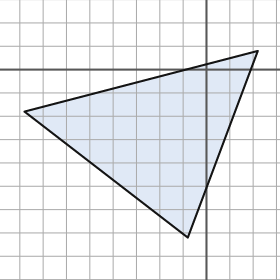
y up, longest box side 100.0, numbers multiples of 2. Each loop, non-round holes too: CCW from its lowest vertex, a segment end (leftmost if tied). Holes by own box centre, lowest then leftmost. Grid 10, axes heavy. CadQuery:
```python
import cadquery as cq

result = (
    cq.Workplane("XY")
    .moveTo(-8.0, -72.0)
    .lineTo(22.0, 8.0)
    .lineTo(-78.0, -18.0)
    .close()
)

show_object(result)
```